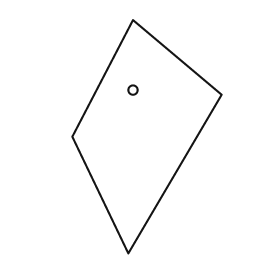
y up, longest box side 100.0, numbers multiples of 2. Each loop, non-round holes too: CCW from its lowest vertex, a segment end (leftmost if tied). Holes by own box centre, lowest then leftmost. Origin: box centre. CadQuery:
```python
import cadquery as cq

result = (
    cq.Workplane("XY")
    .moveTo(-8.0, -50.0)
    .lineTo(32.0, 18.0)
    .lineTo(-6.0, 50.0)
    .lineTo(-32.0, 0.0)
    .close()
    .moveTo(-6.0, 20.0)
    .circle(2.0)
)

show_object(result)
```